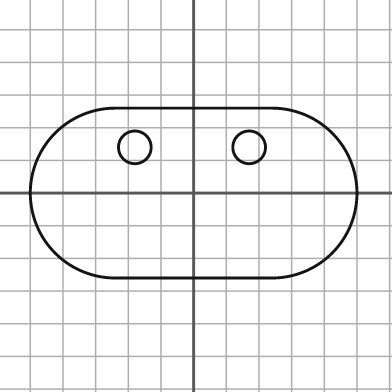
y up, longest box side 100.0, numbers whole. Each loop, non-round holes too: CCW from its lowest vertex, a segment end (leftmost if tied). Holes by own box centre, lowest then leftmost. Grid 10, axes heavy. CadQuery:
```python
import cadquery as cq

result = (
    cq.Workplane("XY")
    .moveTo(-24.0, -26.0)
    .lineTo(24.0, -26.0)
    .threePointArc((50.0, 0.0), (24.0, 26.0))
    .lineTo(-24.0, 26.0)
    .threePointArc((-50.0, 0.0), (-24.0, -26.0))
    .close()
    .moveTo(-18.0, 14.0)
    .circle(5.0)
    .moveTo(17.0, 14.0)
    .circle(5.0)
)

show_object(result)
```